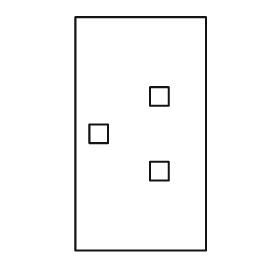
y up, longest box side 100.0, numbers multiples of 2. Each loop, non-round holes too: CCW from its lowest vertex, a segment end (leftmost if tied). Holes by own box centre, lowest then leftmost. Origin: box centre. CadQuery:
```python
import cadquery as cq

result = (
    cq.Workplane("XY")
    .moveTo(-28.0, -50.0)
    .lineTo(28.0, -50.0)
    .lineTo(28.0, 50.0)
    .lineTo(-28.0, 50.0)
    .close()
    .moveTo(4.0, -20.0)
    .lineTo(12.0, -20.0)
    .lineTo(12.0, -12.0)
    .lineTo(4.0, -12.0)
    .close()
    .moveTo(-22.0, -4.0)
    .lineTo(-14.0, -4.0)
    .lineTo(-14.0, 4.0)
    .lineTo(-22.0, 4.0)
    .close()
    .moveTo(4.0, 12.0)
    .lineTo(12.0, 12.0)
    .lineTo(12.0, 20.0)
    .lineTo(4.0, 20.0)
    .close()
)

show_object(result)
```